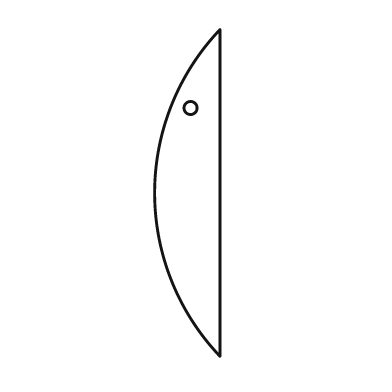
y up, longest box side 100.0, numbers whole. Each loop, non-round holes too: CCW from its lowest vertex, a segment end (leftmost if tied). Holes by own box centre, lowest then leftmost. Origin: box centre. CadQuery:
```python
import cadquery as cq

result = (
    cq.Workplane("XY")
    .moveTo(10.0, -50.0)
    .lineTo(10.0, 50.0)
    .threePointArc((-10.0, 0.0), (10.0, -50.0))
    .close()
    .moveTo(1.0, 26.0)
    .circle(2.0)
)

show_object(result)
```